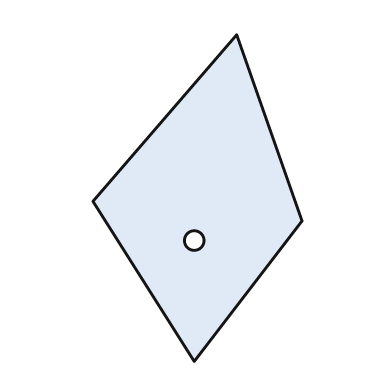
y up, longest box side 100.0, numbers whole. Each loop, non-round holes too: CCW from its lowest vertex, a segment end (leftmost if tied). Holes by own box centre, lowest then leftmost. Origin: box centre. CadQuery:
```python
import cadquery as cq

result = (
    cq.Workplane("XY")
    .moveTo(-1.0, -50.0)
    .lineTo(32.0, -7.0)
    .lineTo(12.0, 50.0)
    .lineTo(-32.0, -1.0)
    .close()
    .moveTo(-1.0, -13.0)
    .circle(3.0)
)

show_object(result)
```